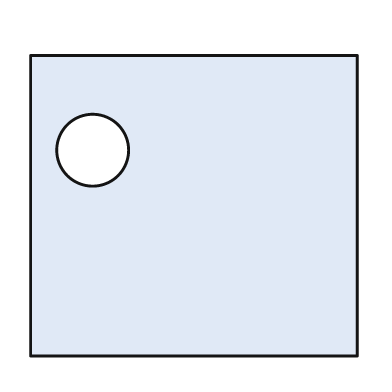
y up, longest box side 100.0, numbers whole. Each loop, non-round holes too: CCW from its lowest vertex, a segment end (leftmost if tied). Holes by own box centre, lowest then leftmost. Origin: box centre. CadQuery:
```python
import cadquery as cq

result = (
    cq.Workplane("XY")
    .moveTo(-50.0, -46.0)
    .lineTo(50.0, -46.0)
    .lineTo(50.0, 46.0)
    .lineTo(-50.0, 46.0)
    .close()
    .moveTo(-31.0, 17.0)
    .circle(11.0)
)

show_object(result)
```